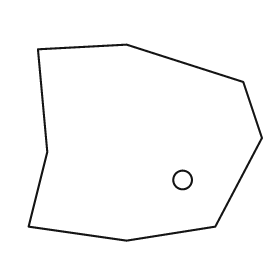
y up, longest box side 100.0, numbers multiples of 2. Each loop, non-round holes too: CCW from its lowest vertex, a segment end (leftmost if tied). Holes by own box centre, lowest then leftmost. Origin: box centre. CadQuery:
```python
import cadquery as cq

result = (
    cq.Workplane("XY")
    .moveTo(-8.0, -42.0)
    .lineTo(30.0, -36.0)
    .lineTo(50.0, 2.0)
    .lineTo(42.0, 26.0)
    .lineTo(-8.0, 42.0)
    .lineTo(-46.0, 40.0)
    .lineTo(-42.0, -4.0)
    .lineTo(-50.0, -36.0)
    .close()
    .moveTo(16.0, -16.0)
    .circle(4.0)
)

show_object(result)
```